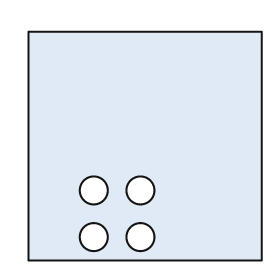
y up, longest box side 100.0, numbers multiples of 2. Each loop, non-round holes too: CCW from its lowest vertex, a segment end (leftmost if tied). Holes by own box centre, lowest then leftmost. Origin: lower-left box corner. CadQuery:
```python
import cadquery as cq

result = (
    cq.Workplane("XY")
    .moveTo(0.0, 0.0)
    .lineTo(100.0, 0.0)
    .lineTo(100.0, 98.0)
    .lineTo(0.0, 98.0)
    .close()
    .moveTo(28.0, 10.0)
    .circle(6.0)
    .moveTo(48.0, 10.0)
    .circle(6.0)
    .moveTo(28.0, 30.0)
    .circle(6.0)
    .moveTo(48.0, 30.0)
    .circle(6.0)
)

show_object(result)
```